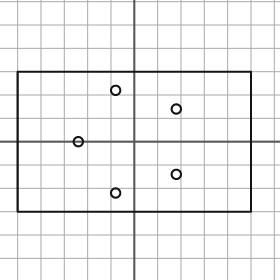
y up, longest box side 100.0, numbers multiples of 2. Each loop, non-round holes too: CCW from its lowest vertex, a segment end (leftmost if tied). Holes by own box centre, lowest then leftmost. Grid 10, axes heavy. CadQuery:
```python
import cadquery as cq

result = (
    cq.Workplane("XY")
    .moveTo(-50.0, -30.0)
    .lineTo(50.0, -30.0)
    .lineTo(50.0, 30.0)
    .lineTo(-50.0, 30.0)
    .close()
    .moveTo(-8.0, -22.0)
    .circle(2.0)
    .moveTo(18.0, -14.0)
    .circle(2.0)
    .moveTo(-24.0, 0.0)
    .circle(2.0)
    .moveTo(18.0, 14.0)
    .circle(2.0)
    .moveTo(-8.0, 22.0)
    .circle(2.0)
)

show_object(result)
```